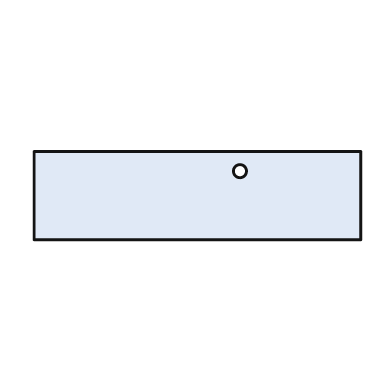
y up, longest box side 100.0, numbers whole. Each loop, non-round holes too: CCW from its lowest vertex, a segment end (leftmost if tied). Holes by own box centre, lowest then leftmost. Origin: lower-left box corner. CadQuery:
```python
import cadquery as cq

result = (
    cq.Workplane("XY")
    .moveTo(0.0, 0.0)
    .lineTo(100.0, 0.0)
    .lineTo(100.0, 27.0)
    .lineTo(0.0, 27.0)
    .close()
    .moveTo(63.0, 21.0)
    .circle(2.0)
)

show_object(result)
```